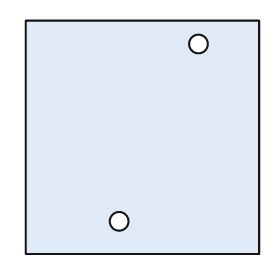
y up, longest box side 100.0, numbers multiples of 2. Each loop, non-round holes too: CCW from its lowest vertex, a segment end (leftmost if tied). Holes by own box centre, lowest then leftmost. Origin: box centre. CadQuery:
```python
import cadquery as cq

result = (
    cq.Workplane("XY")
    .moveTo(-50.0, -50.0)
    .lineTo(50.0, -50.0)
    .lineTo(50.0, 50.0)
    .lineTo(-50.0, 50.0)
    .close()
    .moveTo(-10.0, -36.0)
    .circle(4.0)
    .moveTo(24.0, 40.0)
    .circle(4.0)
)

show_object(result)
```